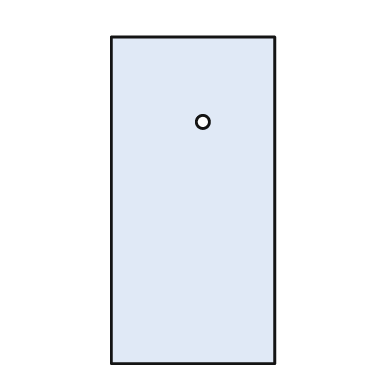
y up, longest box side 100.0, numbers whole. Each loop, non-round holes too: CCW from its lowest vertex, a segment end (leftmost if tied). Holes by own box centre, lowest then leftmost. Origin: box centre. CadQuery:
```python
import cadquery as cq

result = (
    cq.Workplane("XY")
    .moveTo(-25.0, -50.0)
    .lineTo(25.0, -50.0)
    .lineTo(25.0, 50.0)
    .lineTo(-25.0, 50.0)
    .close()
    .moveTo(3.0, 24.0)
    .circle(2.0)
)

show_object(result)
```